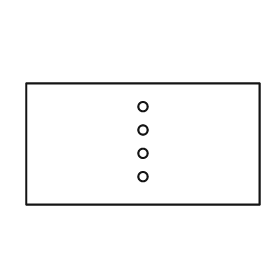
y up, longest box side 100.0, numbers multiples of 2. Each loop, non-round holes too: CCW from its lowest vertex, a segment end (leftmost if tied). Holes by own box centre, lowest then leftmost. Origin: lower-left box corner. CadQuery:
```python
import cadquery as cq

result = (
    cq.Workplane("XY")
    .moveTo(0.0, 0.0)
    .lineTo(100.0, 0.0)
    .lineTo(100.0, 52.0)
    .lineTo(0.0, 52.0)
    .close()
    .moveTo(50.0, 12.0)
    .circle(2.0)
    .moveTo(50.0, 22.0)
    .circle(2.0)
    .moveTo(50.0, 32.0)
    .circle(2.0)
    .moveTo(50.0, 42.0)
    .circle(2.0)
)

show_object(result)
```